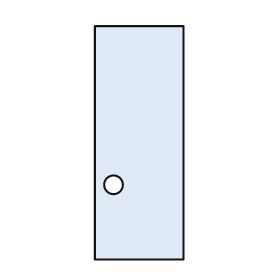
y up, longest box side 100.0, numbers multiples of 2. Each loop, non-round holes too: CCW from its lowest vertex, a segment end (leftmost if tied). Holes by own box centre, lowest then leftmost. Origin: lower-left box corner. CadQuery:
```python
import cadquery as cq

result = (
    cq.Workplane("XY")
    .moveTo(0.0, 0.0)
    .lineTo(38.0, 0.0)
    .lineTo(38.0, 100.0)
    .lineTo(0.0, 100.0)
    .close()
    .moveTo(8.0, 32.0)
    .circle(4.0)
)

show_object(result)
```